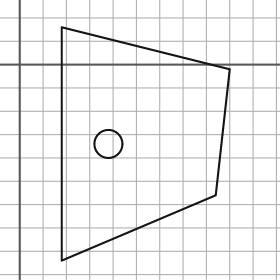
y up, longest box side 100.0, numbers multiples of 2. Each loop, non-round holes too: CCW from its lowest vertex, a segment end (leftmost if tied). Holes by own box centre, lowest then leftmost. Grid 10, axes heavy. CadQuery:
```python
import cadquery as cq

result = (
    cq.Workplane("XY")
    .moveTo(18.0, -84.0)
    .lineTo(84.0, -56.0)
    .lineTo(90.0, -2.0)
    .lineTo(18.0, 16.0)
    .close()
    .moveTo(38.0, -34.0)
    .circle(6.0)
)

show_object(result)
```